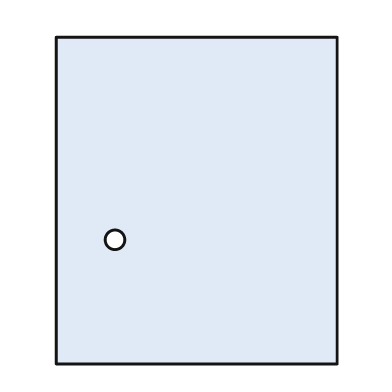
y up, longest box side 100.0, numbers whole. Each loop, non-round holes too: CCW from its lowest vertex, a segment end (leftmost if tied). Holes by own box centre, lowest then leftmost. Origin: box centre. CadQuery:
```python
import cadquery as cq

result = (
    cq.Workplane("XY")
    .moveTo(-43.0, -50.0)
    .lineTo(43.0, -50.0)
    .lineTo(43.0, 50.0)
    .lineTo(-43.0, 50.0)
    .close()
    .moveTo(-25.0, -12.0)
    .circle(3.0)
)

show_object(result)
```